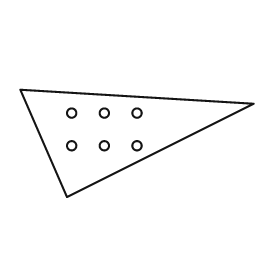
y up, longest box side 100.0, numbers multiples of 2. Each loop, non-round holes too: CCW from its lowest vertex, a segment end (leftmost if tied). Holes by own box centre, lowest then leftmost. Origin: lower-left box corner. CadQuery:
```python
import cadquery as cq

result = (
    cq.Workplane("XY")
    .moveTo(20.0, 0.0)
    .lineTo(100.0, 40.0)
    .lineTo(0.0, 46.0)
    .close()
    .moveTo(22.0, 22.0)
    .circle(2.0)
    .moveTo(36.0, 22.0)
    .circle(2.0)
    .moveTo(50.0, 22.0)
    .circle(2.0)
    .moveTo(22.0, 36.0)
    .circle(2.0)
    .moveTo(36.0, 36.0)
    .circle(2.0)
    .moveTo(50.0, 36.0)
    .circle(2.0)
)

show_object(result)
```